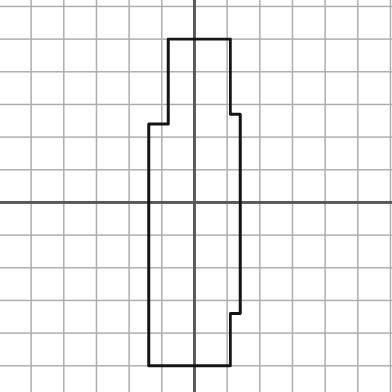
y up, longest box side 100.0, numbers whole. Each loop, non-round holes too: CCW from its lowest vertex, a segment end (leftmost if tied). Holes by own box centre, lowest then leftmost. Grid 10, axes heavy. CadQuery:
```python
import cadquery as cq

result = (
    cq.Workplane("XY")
    .moveTo(-14.0, -50.0)
    .lineTo(11.0, -50.0)
    .lineTo(11.0, -34.0)
    .lineTo(14.0, -34.0)
    .lineTo(14.0, 27.0)
    .lineTo(11.0, 27.0)
    .lineTo(11.0, 50.0)
    .lineTo(-8.0, 50.0)
    .lineTo(-8.0, 24.0)
    .lineTo(-14.0, 24.0)
    .close()
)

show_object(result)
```